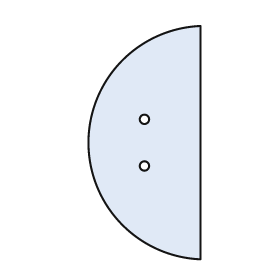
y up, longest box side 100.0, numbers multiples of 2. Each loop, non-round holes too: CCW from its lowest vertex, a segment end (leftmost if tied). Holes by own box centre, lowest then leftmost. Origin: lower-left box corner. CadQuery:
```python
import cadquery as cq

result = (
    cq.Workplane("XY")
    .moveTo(48.0, 0.0)
    .lineTo(48.0, 100.0)
    .threePointArc((0.0, 50.0), (48.0, 0.0))
    .close()
    .moveTo(24.0, 40.0)
    .circle(2.0)
    .moveTo(24.0, 60.0)
    .circle(2.0)
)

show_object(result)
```